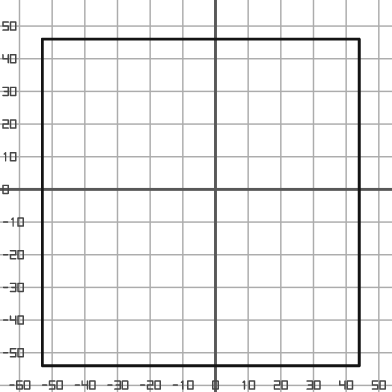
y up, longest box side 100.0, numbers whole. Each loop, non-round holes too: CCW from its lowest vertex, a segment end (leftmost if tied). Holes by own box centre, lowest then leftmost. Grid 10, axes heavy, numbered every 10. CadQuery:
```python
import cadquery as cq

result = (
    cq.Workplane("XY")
    .moveTo(-53.0, -54.0)
    .lineTo(44.0, -54.0)
    .lineTo(44.0, 46.0)
    .lineTo(-53.0, 46.0)
    .close()
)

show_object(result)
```